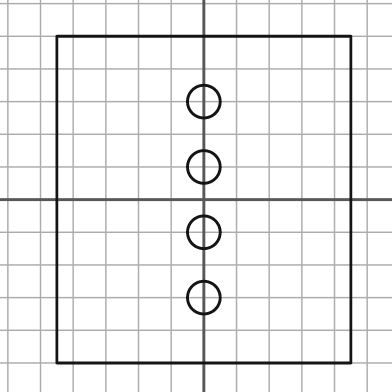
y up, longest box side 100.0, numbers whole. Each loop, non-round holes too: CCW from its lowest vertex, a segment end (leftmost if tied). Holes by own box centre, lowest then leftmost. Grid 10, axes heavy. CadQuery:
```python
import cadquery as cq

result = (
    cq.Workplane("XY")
    .moveTo(-45.0, -50.0)
    .lineTo(45.0, -50.0)
    .lineTo(45.0, 50.0)
    .lineTo(-45.0, 50.0)
    .close()
    .moveTo(0.0, -30.0)
    .circle(5.0)
    .moveTo(0.0, -10.0)
    .circle(5.0)
    .moveTo(0.0, 10.0)
    .circle(5.0)
    .moveTo(0.0, 30.0)
    .circle(5.0)
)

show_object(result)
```